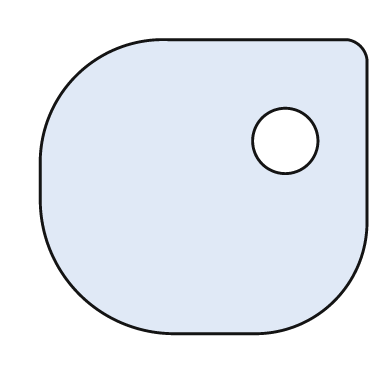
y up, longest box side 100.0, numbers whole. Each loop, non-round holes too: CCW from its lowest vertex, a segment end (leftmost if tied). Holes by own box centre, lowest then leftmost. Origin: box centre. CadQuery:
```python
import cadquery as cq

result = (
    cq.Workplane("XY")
    .moveTo(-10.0, -45.0)
    .lineTo(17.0, -45.0)
    .threePointArc((40.0, -35.0), (50.0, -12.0))
    .lineTo(50.0, 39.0)
    .threePointArc((48.0, 43.0), (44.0, 45.0))
    .lineTo(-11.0, 45.0)
    .threePointArc((-39.0, 34.0), (-50.0, 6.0))
    .lineTo(-50.0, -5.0)
    .threePointArc((-38.0, -33.0), (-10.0, -45.0))
    .close()
    .moveTo(25.0, 14.0)
    .circle(10.0)
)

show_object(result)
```